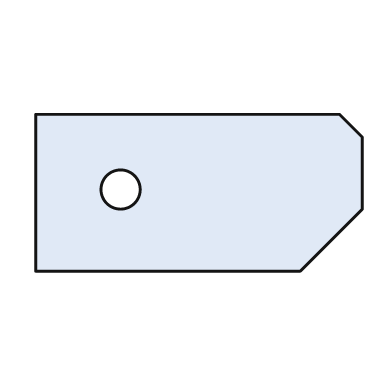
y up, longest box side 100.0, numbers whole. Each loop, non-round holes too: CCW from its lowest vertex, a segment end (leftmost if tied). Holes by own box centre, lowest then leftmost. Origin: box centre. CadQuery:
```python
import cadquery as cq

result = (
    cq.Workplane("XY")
    .moveTo(-50.0, -24.0)
    .lineTo(31.0, -24.0)
    .lineTo(50.0, -5.0)
    .lineTo(50.0, 17.0)
    .lineTo(43.0, 24.0)
    .lineTo(-50.0, 24.0)
    .close()
    .moveTo(-24.0, 1.0)
    .circle(6.0)
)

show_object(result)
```